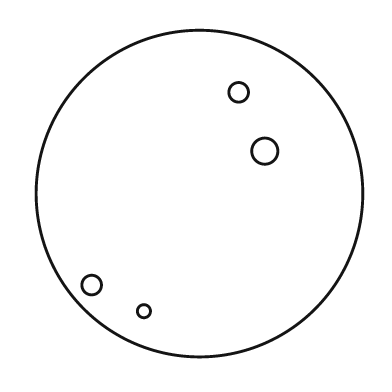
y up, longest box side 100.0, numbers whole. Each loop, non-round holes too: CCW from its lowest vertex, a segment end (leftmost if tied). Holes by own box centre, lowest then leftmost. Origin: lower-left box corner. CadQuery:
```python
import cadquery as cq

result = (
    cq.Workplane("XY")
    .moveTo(50.0, 50.0)
    .circle(50.0)
    .moveTo(33.0, 14.0)
    .circle(2.0)
    .moveTo(17.0, 22.0)
    .circle(3.0)
    .moveTo(70.0, 63.0)
    .circle(4.0)
    .moveTo(62.0, 81.0)
    .circle(3.0)
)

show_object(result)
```